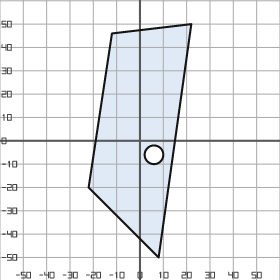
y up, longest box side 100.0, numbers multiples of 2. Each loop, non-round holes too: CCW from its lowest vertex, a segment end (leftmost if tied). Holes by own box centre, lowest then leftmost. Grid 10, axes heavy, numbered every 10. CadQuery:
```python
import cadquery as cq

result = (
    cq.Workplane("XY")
    .moveTo(8.0, -50.0)
    .lineTo(22.0, 50.0)
    .lineTo(-12.0, 46.0)
    .lineTo(-22.0, -20.0)
    .close()
    .moveTo(6.0, -6.0)
    .circle(4.0)
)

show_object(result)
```